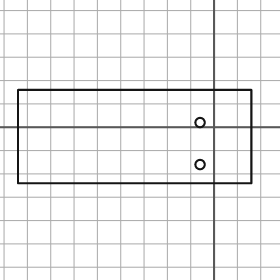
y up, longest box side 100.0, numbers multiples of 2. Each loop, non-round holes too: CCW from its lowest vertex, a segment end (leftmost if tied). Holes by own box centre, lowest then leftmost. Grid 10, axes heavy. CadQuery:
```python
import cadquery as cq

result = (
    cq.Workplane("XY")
    .moveTo(-84.0, -24.0)
    .lineTo(16.0, -24.0)
    .lineTo(16.0, 16.0)
    .lineTo(-84.0, 16.0)
    .close()
    .moveTo(-6.0, -16.0)
    .circle(2.0)
    .moveTo(-6.0, 2.0)
    .circle(2.0)
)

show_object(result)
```